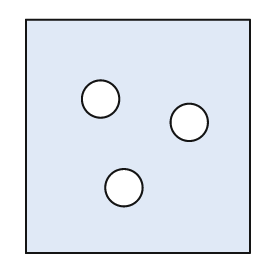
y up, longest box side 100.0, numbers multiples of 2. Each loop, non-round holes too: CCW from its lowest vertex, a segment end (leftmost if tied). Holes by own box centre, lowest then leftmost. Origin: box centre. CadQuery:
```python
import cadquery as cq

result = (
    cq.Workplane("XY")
    .moveTo(-48.0, -50.0)
    .lineTo(48.0, -50.0)
    .lineTo(48.0, 50.0)
    .lineTo(-48.0, 50.0)
    .close()
    .moveTo(-6.0, -22.0)
    .circle(8.0)
    .moveTo(22.0, 6.0)
    .circle(8.0)
    .moveTo(-16.0, 16.0)
    .circle(8.0)
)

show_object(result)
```